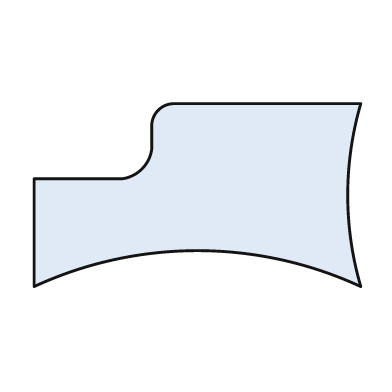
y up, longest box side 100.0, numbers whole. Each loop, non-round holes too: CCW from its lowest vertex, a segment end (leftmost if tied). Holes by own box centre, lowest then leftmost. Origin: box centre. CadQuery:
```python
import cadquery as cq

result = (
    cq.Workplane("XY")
    .moveTo(-50.0, -28.0)
    .threePointArc((0.0, -17.0), (50.0, -28.0))
    .threePointArc((46.0, 0.0), (50.0, 28.0))
    .lineTo(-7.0, 28.0)
    .threePointArc((-12.0, 26.0), (-14.0, 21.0))
    .lineTo(-14.0, 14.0)
    .threePointArc((-17.0, 8.0), (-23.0, 5.0))
    .lineTo(-50.0, 5.0)
    .close()
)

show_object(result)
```